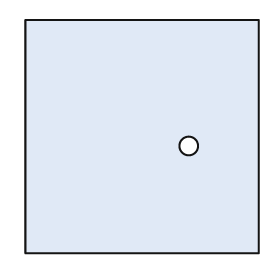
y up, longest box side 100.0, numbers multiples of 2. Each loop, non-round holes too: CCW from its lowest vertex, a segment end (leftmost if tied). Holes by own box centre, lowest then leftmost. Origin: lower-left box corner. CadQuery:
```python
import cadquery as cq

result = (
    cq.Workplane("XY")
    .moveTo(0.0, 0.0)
    .lineTo(100.0, 0.0)
    .lineTo(100.0, 100.0)
    .lineTo(0.0, 100.0)
    .close()
    .moveTo(70.0, 46.0)
    .circle(4.0)
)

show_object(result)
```